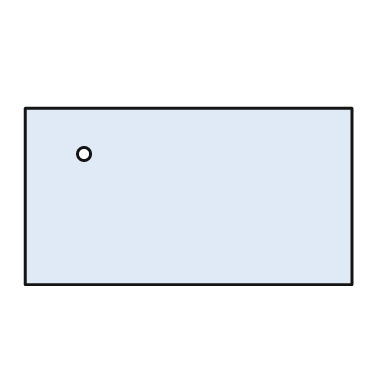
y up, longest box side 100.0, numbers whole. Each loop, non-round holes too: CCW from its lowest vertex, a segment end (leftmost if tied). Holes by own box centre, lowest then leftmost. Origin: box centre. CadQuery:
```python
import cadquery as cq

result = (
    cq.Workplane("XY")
    .moveTo(-50.0, -27.0)
    .lineTo(50.0, -27.0)
    .lineTo(50.0, 27.0)
    .lineTo(-50.0, 27.0)
    .close()
    .moveTo(-32.0, 13.0)
    .circle(2.0)
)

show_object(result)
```